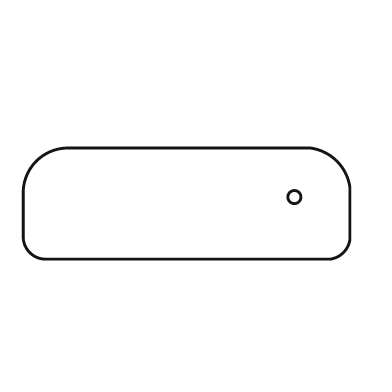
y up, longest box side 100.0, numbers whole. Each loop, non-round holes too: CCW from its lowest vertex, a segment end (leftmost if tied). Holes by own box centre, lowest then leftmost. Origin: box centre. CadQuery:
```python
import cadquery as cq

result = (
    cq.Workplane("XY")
    .moveTo(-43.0, -17.0)
    .lineTo(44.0, -17.0)
    .threePointArc((48.0, -15.0), (50.0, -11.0))
    .lineTo(50.0, 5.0)
    .threePointArc((46.0, 13.0), (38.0, 17.0))
    .lineTo(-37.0, 17.0)
    .threePointArc((-46.0, 13.0), (-50.0, 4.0))
    .lineTo(-50.0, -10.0)
    .threePointArc((-48.0, -15.0), (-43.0, -17.0))
    .close()
    .moveTo(33.0, 2.0)
    .circle(2.0)
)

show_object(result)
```